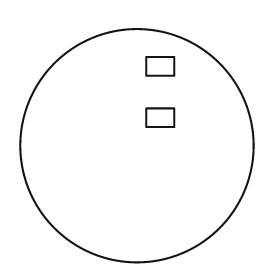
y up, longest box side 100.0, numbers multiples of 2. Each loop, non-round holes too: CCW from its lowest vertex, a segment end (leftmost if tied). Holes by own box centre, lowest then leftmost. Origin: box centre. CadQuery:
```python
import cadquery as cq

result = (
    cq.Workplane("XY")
    .moveTo(0.0, 0.0)
    .circle(50.0)
    .moveTo(4.0, 8.0)
    .lineTo(16.0, 8.0)
    .lineTo(16.0, 16.0)
    .lineTo(4.0, 16.0)
    .close()
    .moveTo(4.0, 30.0)
    .lineTo(16.0, 30.0)
    .lineTo(16.0, 38.0)
    .lineTo(4.0, 38.0)
    .close()
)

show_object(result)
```